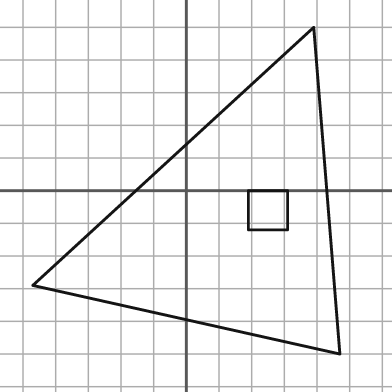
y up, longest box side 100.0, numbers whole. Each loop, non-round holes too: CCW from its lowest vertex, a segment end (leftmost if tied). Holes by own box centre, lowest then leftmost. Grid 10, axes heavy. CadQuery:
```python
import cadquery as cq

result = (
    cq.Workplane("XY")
    .moveTo(47.0, -50.0)
    .lineTo(39.0, 50.0)
    .lineTo(-47.0, -29.0)
    .close()
    .moveTo(19.0, -12.0)
    .lineTo(31.0, -12.0)
    .lineTo(31.0, 0.0)
    .lineTo(19.0, 0.0)
    .close()
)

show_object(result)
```